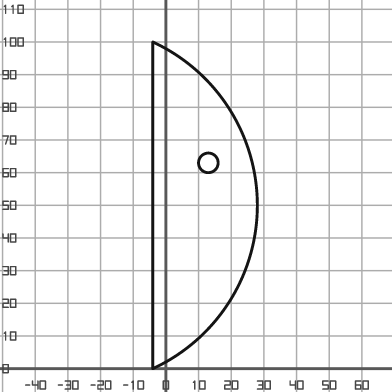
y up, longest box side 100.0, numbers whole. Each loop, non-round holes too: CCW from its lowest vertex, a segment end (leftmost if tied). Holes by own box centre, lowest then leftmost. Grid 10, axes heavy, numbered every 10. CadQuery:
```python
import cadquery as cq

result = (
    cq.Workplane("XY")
    .moveTo(-4.0, 0.0)
    .threePointArc((28.0, 50.0), (-4.0, 100.0))
    .close()
    .moveTo(13.0, 63.0)
    .circle(3.0)
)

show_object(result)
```